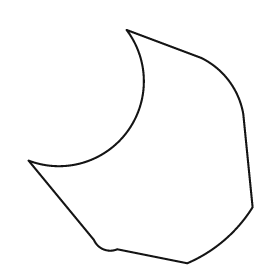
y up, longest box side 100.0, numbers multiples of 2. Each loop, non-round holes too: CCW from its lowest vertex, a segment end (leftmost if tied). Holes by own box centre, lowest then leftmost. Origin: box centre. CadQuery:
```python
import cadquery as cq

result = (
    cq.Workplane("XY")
    .moveTo(20.0, -50.0)
    .threePointArc((36.0, -40.0), (48.0, -26.0))
    .lineTo(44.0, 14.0)
    .threePointArc((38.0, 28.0), (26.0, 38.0))
    .lineTo(-6.0, 50.0)
    .threePointArc((-6.0, 6.0), (-48.0, -6.0))
    .lineTo(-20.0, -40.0)
    .threePointArc((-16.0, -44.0), (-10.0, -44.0))
    .close()
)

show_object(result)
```